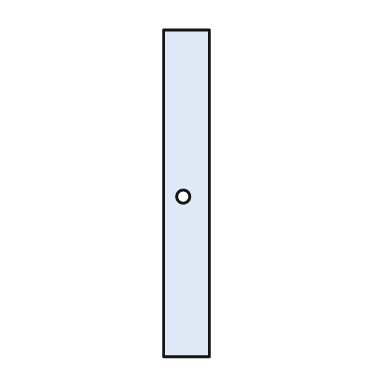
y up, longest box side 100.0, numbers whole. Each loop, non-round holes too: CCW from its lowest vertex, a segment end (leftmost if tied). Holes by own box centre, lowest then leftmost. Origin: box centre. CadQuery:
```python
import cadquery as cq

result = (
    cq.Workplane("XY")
    .moveTo(-7.0, -50.0)
    .lineTo(7.0, -50.0)
    .lineTo(7.0, 50.0)
    .lineTo(-7.0, 50.0)
    .close()
    .moveTo(-1.0, -1.0)
    .circle(2.0)
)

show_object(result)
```